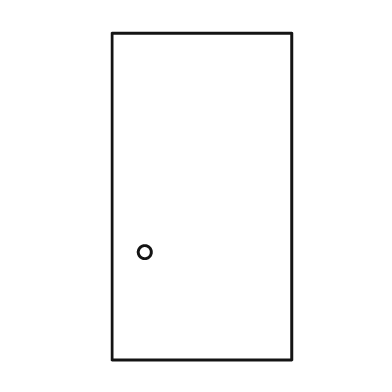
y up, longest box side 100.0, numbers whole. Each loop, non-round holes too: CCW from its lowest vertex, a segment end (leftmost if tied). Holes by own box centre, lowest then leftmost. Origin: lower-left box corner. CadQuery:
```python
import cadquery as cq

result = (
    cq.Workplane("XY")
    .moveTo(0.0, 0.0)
    .lineTo(55.0, 0.0)
    .lineTo(55.0, 100.0)
    .lineTo(0.0, 100.0)
    .close()
    .moveTo(10.0, 33.0)
    .circle(2.0)
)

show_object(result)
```